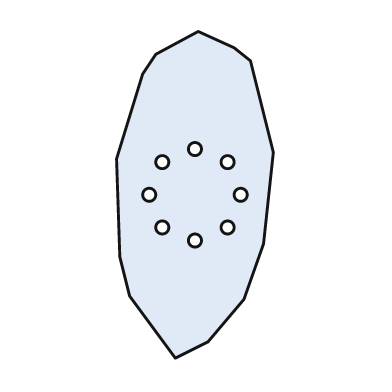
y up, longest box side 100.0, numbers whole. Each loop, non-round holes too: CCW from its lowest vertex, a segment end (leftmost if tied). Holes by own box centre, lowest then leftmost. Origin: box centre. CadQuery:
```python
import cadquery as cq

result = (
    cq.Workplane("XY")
    .moveTo(-6.0, -50.0)
    .lineTo(4.0, -45.0)
    .lineTo(15.0, -32.0)
    .lineTo(21.0, -15.0)
    .lineTo(24.0, 13.0)
    .lineTo(17.0, 41.0)
    .lineTo(12.0, 45.0)
    .lineTo(1.0, 50.0)
    .lineTo(-12.0, 43.0)
    .lineTo(-16.0, 37.0)
    .lineTo(-24.0, 11.0)
    .lineTo(-23.0, -19.0)
    .lineTo(-20.0, -31.0)
    .close()
    .moveTo(0.0, -14.0)
    .circle(2.0)
    .moveTo(-10.0, -10.0)
    .circle(2.0)
    .moveTo(10.0, -10.0)
    .circle(2.0)
    .moveTo(-14.0, 0.0)
    .circle(2.0)
    .moveTo(14.0, 0.0)
    .circle(2.0)
    .moveTo(-10.0, 10.0)
    .circle(2.0)
    .moveTo(10.0, 10.0)
    .circle(2.0)
    .moveTo(0.0, 14.0)
    .circle(2.0)
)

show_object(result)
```